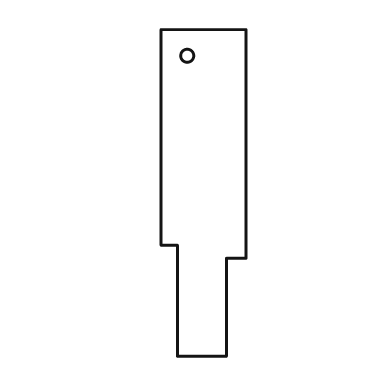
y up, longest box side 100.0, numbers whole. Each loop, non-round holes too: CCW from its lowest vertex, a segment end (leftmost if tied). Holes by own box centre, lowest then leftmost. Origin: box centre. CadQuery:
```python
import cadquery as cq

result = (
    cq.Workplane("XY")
    .moveTo(-8.0, -50.0)
    .lineTo(7.0, -50.0)
    .lineTo(7.0, -20.0)
    .lineTo(13.0, -20.0)
    .lineTo(13.0, 50.0)
    .lineTo(-13.0, 50.0)
    .lineTo(-13.0, -16.0)
    .lineTo(-8.0, -16.0)
    .close()
    .moveTo(-5.0, 42.0)
    .circle(2.0)
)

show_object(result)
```